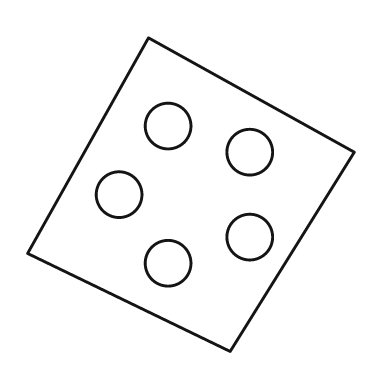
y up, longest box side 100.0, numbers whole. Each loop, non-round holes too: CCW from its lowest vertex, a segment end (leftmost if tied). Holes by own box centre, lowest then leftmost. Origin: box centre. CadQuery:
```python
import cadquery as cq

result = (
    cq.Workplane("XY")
    .moveTo(12.0, -48.0)
    .lineTo(50.0, 13.0)
    .lineTo(-13.0, 48.0)
    .lineTo(-50.0, -18.0)
    .close()
    .moveTo(-7.0, -21.0)
    .circle(7.0)
    .moveTo(18.0, -13.0)
    .circle(7.0)
    .moveTo(-22.0, 0.0)
    .circle(7.0)
    .moveTo(18.0, 13.0)
    .circle(7.0)
    .moveTo(-7.0, 21.0)
    .circle(7.0)
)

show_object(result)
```